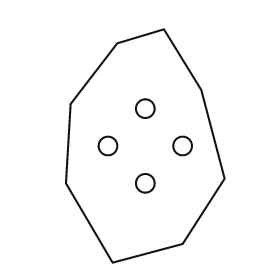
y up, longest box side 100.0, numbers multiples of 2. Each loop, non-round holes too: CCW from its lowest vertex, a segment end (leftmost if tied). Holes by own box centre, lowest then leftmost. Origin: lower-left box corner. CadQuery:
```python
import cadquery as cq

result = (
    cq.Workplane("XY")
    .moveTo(20.0, 0.0)
    .lineTo(50.0, 8.0)
    .lineTo(68.0, 36.0)
    .lineTo(58.0, 74.0)
    .lineTo(42.0, 100.0)
    .lineTo(22.0, 94.0)
    .lineTo(2.0, 68.0)
    .lineTo(0.0, 34.0)
    .close()
    .moveTo(34.0, 34.0)
    .circle(4.0)
    .moveTo(18.0, 50.0)
    .circle(4.0)
    .moveTo(50.0, 50.0)
    .circle(4.0)
    .moveTo(34.0, 66.0)
    .circle(4.0)
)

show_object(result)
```